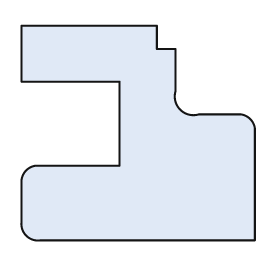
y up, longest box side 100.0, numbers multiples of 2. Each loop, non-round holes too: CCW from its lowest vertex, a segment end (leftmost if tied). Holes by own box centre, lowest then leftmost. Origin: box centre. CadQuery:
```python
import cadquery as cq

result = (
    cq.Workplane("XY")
    .moveTo(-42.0, -46.0)
    .lineTo(50.0, -46.0)
    .lineTo(50.0, 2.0)
    .threePointArc((48.0, 6.0), (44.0, 8.0))
    .lineTo(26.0, 8.0)
    .threePointArc((18.0, 10.0), (16.0, 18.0))
    .lineTo(16.0, 36.0)
    .lineTo(8.0, 36.0)
    .lineTo(8.0, 46.0)
    .lineTo(-50.0, 46.0)
    .lineTo(-50.0, 22.0)
    .lineTo(-8.0, 22.0)
    .lineTo(-8.0, -14.0)
    .lineTo(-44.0, -14.0)
    .threePointArc((-48.0, -16.0), (-50.0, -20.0))
    .lineTo(-50.0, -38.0)
    .threePointArc((-48.0, -44.0), (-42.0, -46.0))
    .close()
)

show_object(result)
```